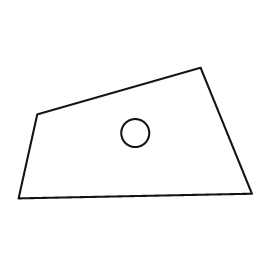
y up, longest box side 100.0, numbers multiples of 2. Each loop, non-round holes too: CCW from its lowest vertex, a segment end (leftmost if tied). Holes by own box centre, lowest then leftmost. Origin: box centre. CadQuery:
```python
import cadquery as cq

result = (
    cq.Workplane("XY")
    .moveTo(-50.0, -28.0)
    .lineTo(50.0, -26.0)
    .lineTo(28.0, 28.0)
    .lineTo(-42.0, 8.0)
    .close()
    .moveTo(0.0, 0.0)
    .circle(6.0)
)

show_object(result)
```